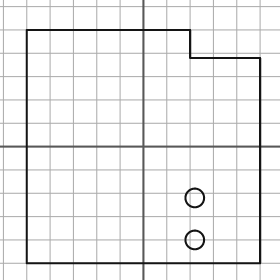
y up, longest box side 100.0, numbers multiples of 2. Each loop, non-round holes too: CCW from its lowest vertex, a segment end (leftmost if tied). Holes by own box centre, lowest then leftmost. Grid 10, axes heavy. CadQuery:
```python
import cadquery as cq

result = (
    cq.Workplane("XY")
    .moveTo(-50.0, -50.0)
    .lineTo(50.0, -50.0)
    .lineTo(50.0, 38.0)
    .lineTo(20.0, 38.0)
    .lineTo(20.0, 50.0)
    .lineTo(-50.0, 50.0)
    .close()
    .moveTo(22.0, -40.0)
    .circle(4.0)
    .moveTo(22.0, -22.0)
    .circle(4.0)
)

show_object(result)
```